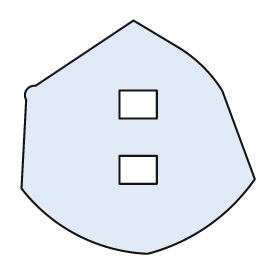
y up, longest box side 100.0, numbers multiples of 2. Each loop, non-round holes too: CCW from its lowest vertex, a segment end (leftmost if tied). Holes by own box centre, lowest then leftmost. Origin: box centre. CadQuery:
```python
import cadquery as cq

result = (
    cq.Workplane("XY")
    .moveTo(4.0, -50.0)
    .threePointArc((30.0, -38.0), (50.0, -18.0))
    .lineTo(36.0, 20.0)
    .threePointArc((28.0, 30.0), (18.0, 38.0))
    .lineTo(-2.0, 50.0)
    .lineTo(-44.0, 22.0)
    .threePointArc((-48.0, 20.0), (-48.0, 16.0))
    .lineTo(-50.0, -22.0)
    .threePointArc((-26.0, -42.0), (4.0, -50.0))
    .close()
    .moveTo(-8.0, -20.0)
    .lineTo(8.0, -20.0)
    .lineTo(8.0, -8.0)
    .lineTo(-8.0, -8.0)
    .close()
    .moveTo(-8.0, 8.0)
    .lineTo(8.0, 8.0)
    .lineTo(8.0, 20.0)
    .lineTo(-8.0, 20.0)
    .close()
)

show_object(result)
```